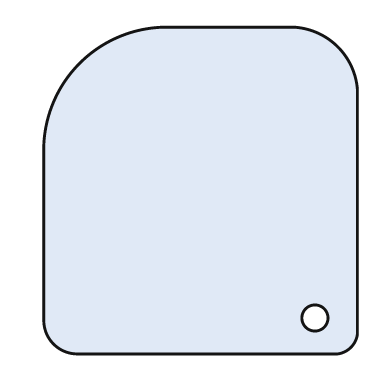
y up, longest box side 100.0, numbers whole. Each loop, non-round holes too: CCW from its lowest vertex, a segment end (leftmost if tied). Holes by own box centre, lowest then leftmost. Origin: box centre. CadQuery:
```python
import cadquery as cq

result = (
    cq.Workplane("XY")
    .moveTo(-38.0, -50.0)
    .lineTo(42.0, -50.0)
    .threePointArc((46.0, -48.0), (48.0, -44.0))
    .lineTo(48.0, 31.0)
    .threePointArc((42.0, 44.0), (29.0, 50.0))
    .lineTo(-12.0, 50.0)
    .threePointArc((-37.0, 39.0), (-48.0, 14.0))
    .lineTo(-48.0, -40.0)
    .threePointArc((-45.0, -47.0), (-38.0, -50.0))
    .close()
    .moveTo(35.0, -39.0)
    .circle(4.0)
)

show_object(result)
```